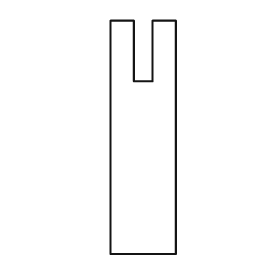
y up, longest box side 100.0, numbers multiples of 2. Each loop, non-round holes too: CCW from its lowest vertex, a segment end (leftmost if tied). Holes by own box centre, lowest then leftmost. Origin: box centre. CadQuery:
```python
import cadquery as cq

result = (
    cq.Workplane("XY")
    .moveTo(-14.0, -50.0)
    .lineTo(14.0, -50.0)
    .lineTo(14.0, 50.0)
    .lineTo(4.0, 50.0)
    .lineTo(4.0, 24.0)
    .lineTo(-4.0, 24.0)
    .lineTo(-4.0, 50.0)
    .lineTo(-14.0, 50.0)
    .close()
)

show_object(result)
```